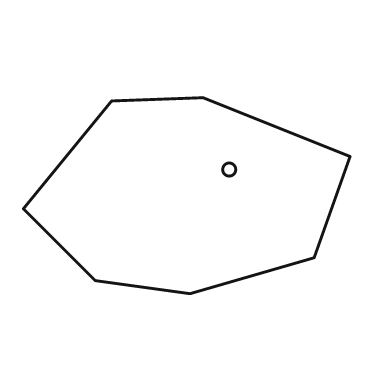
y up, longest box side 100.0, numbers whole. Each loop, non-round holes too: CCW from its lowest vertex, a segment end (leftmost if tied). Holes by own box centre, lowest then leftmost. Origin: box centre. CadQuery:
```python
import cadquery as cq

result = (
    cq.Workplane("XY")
    .moveTo(1.0, -30.0)
    .lineTo(39.0, -19.0)
    .lineTo(50.0, 12.0)
    .lineTo(5.0, 30.0)
    .lineTo(-23.0, 29.0)
    .lineTo(-50.0, -4.0)
    .lineTo(-28.0, -26.0)
    .close()
    .moveTo(13.0, 8.0)
    .circle(2.0)
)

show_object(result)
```